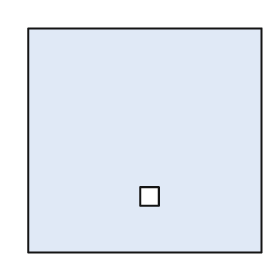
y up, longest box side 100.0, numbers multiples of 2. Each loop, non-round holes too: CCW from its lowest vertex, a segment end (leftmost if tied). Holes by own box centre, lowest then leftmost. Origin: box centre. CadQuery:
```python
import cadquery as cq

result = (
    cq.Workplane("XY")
    .moveTo(-50.0, -48.0)
    .lineTo(50.0, -48.0)
    .lineTo(50.0, 48.0)
    .lineTo(-50.0, 48.0)
    .close()
    .moveTo(-2.0, -28.0)
    .lineTo(6.0, -28.0)
    .lineTo(6.0, -20.0)
    .lineTo(-2.0, -20.0)
    .close()
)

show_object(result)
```